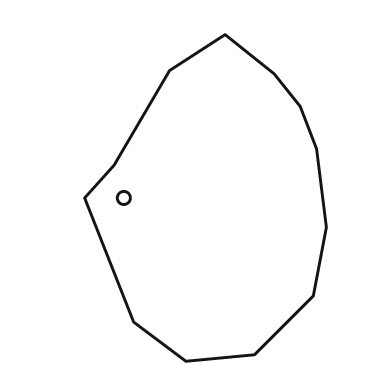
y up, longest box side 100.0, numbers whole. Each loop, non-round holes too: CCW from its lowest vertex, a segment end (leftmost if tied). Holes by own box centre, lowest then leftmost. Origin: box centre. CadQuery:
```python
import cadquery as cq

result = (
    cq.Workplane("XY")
    .moveTo(-6.0, -50.0)
    .lineTo(15.0, -48.0)
    .lineTo(33.0, -30.0)
    .lineTo(37.0, -9.0)
    .lineTo(34.0, 15.0)
    .lineTo(29.0, 28.0)
    .lineTo(21.0, 38.0)
    .lineTo(6.0, 50.0)
    .lineTo(-11.0, 39.0)
    .lineTo(-28.0, 10.0)
    .lineTo(-37.0, 0.0)
    .lineTo(-22.0, -38.0)
    .close()
    .moveTo(-25.0, 0.0)
    .circle(2.0)
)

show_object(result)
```